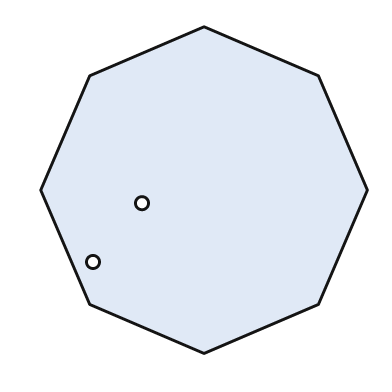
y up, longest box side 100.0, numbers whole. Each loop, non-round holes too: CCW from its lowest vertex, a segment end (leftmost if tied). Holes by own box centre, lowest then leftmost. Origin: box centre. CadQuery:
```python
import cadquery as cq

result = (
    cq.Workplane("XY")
    .moveTo(0.0, -50.0)
    .lineTo(35.0, -35.0)
    .lineTo(50.0, 0.0)
    .lineTo(35.0, 35.0)
    .lineTo(0.0, 50.0)
    .lineTo(-35.0, 35.0)
    .lineTo(-50.0, 0.0)
    .lineTo(-35.0, -35.0)
    .close()
    .moveTo(-34.0, -22.0)
    .circle(2.0)
    .moveTo(-19.0, -4.0)
    .circle(2.0)
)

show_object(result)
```